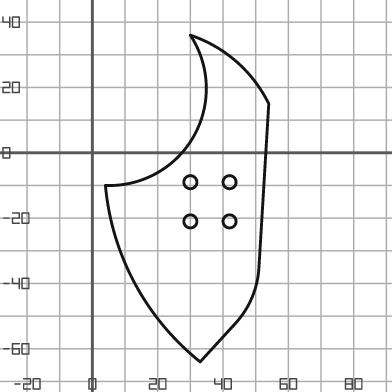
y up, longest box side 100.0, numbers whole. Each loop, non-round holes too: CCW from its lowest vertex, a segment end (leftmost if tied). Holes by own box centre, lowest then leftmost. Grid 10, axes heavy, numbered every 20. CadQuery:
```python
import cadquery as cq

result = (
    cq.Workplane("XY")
    .moveTo(33.0, -64.0)
    .lineTo(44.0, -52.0)
    .threePointArc((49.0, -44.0), (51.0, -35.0))
    .lineTo(54.0, 15.0)
    .threePointArc((44.0, 28.0), (30.0, 36.0))
    .threePointArc((31.0, 5.0), (4.0, -10.0))
    .threePointArc((13.0, -40.0), (33.0, -64.0))
    .close()
    .moveTo(30.0, -21.0)
    .circle(2.0)
    .moveTo(42.0, -21.0)
    .circle(2.0)
    .moveTo(30.0, -9.0)
    .circle(2.0)
    .moveTo(42.0, -9.0)
    .circle(2.0)
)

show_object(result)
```